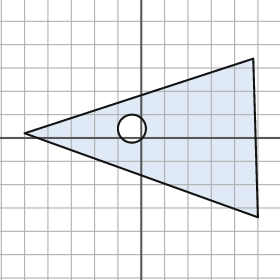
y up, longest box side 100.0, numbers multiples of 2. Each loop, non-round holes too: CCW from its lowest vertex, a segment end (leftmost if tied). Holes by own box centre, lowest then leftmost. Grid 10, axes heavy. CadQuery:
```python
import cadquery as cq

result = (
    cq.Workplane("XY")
    .moveTo(50.0, -34.0)
    .lineTo(48.0, 34.0)
    .lineTo(-50.0, 2.0)
    .close()
    .moveTo(-4.0, 4.0)
    .circle(6.0)
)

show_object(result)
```